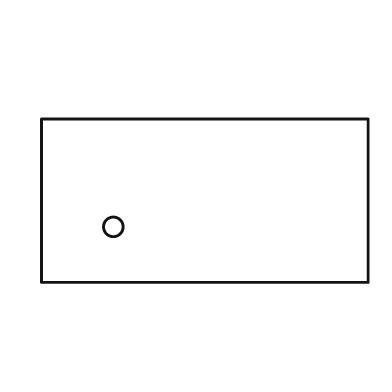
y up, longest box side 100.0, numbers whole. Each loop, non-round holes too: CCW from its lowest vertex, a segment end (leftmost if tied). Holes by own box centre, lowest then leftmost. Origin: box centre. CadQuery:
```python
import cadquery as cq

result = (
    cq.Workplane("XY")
    .moveTo(-50.0, -25.0)
    .lineTo(50.0, -25.0)
    .lineTo(50.0, 25.0)
    .lineTo(-50.0, 25.0)
    .close()
    .moveTo(-28.0, -8.0)
    .circle(3.0)
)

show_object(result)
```